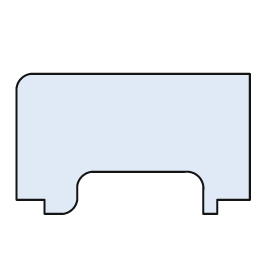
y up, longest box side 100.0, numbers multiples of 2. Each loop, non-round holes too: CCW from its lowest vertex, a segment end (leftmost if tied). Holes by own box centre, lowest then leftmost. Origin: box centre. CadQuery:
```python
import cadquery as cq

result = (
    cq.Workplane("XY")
    .moveTo(-38.0, -30.0)
    .lineTo(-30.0, -30.0)
    .threePointArc((-26.0, -28.0), (-24.0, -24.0))
    .lineTo(-24.0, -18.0)
    .threePointArc((-22.0, -14.0), (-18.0, -12.0))
    .lineTo(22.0, -12.0)
    .threePointArc((28.0, -14.0), (30.0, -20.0))
    .lineTo(30.0, -30.0)
    .lineTo(36.0, -30.0)
    .lineTo(36.0, -24.0)
    .lineTo(50.0, -24.0)
    .lineTo(50.0, 30.0)
    .lineTo(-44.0, 30.0)
    .threePointArc((-48.0, 28.0), (-50.0, 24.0))
    .lineTo(-50.0, -24.0)
    .lineTo(-38.0, -24.0)
    .close()
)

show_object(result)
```